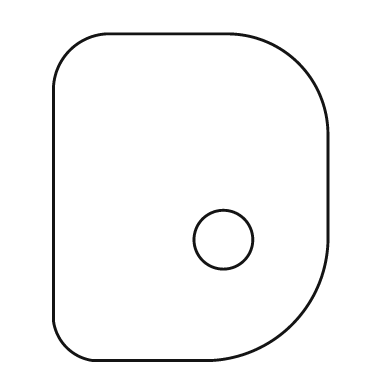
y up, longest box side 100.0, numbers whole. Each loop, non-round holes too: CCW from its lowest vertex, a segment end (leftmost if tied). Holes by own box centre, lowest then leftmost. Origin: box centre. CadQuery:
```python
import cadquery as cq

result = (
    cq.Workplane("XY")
    .moveTo(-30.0, -50.0)
    .lineTo(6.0, -50.0)
    .threePointArc((31.0, -39.0), (42.0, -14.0))
    .lineTo(42.0, 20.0)
    .threePointArc((33.0, 41.0), (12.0, 50.0))
    .lineTo(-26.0, 50.0)
    .threePointArc((-37.0, 45.0), (-42.0, 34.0))
    .lineTo(-42.0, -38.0)
    .threePointArc((-38.0, -46.0), (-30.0, -50.0))
    .close()
    .moveTo(10.0, -13.0)
    .circle(9.0)
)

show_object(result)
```